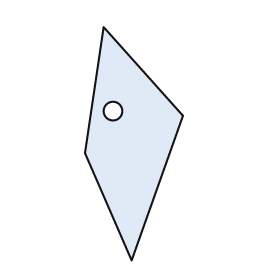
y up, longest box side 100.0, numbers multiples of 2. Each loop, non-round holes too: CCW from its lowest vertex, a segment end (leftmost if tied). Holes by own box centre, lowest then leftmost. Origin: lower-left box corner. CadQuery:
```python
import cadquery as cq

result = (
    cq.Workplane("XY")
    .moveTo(20.0, 0.0)
    .lineTo(42.0, 62.0)
    .lineTo(8.0, 100.0)
    .lineTo(0.0, 46.0)
    .close()
    .moveTo(12.0, 64.0)
    .circle(4.0)
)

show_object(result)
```